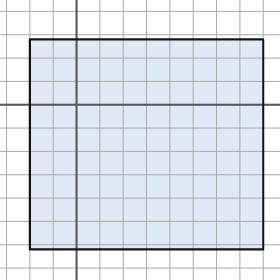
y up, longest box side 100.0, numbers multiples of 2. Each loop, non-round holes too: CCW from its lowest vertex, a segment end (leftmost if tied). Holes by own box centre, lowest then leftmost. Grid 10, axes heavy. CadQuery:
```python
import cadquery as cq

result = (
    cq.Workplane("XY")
    .moveTo(-20.0, -62.0)
    .lineTo(80.0, -62.0)
    .lineTo(80.0, 28.0)
    .lineTo(-20.0, 28.0)
    .close()
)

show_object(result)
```